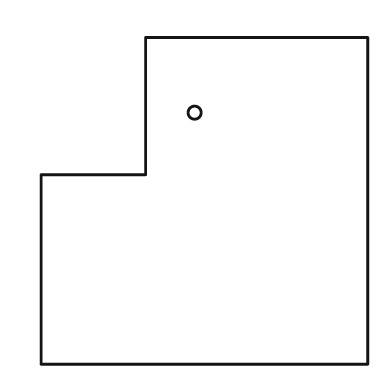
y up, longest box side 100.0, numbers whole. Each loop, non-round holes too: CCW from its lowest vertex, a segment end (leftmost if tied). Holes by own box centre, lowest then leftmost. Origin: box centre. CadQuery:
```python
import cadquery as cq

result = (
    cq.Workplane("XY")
    .moveTo(-50.0, -50.0)
    .lineTo(50.0, -50.0)
    .lineTo(50.0, 50.0)
    .lineTo(-18.0, 50.0)
    .lineTo(-18.0, 8.0)
    .lineTo(-50.0, 8.0)
    .close()
    .moveTo(-3.0, 27.0)
    .circle(2.0)
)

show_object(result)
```